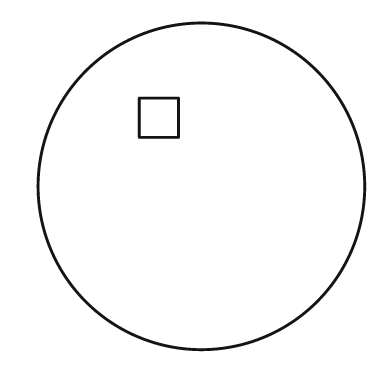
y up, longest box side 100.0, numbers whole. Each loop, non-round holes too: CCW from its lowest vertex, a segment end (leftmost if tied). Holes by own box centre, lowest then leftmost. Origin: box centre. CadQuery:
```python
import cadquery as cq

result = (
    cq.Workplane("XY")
    .moveTo(0.0, 0.0)
    .circle(50.0)
    .moveTo(-19.0, 15.0)
    .lineTo(-7.0, 15.0)
    .lineTo(-7.0, 27.0)
    .lineTo(-19.0, 27.0)
    .close()
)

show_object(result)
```